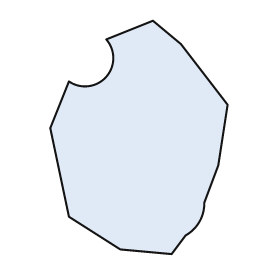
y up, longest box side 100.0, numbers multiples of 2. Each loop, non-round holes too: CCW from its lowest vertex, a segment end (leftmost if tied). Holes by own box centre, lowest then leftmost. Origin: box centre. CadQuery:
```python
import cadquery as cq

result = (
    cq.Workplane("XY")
    .moveTo(14.0, -50.0)
    .lineTo(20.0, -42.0)
    .threePointArc((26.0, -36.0), (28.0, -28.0))
    .lineTo(34.0, -12.0)
    .lineTo(38.0, 14.0)
    .lineTo(18.0, 40.0)
    .lineTo(6.0, 50.0)
    .lineTo(-14.0, 42.0)
    .threePointArc((-14.0, 26.0), (-30.0, 24.0))
    .lineTo(-38.0, 4.0)
    .lineTo(-30.0, -34.0)
    .lineTo(-8.0, -48.0)
    .close()
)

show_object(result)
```